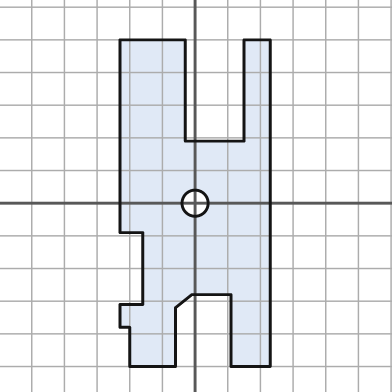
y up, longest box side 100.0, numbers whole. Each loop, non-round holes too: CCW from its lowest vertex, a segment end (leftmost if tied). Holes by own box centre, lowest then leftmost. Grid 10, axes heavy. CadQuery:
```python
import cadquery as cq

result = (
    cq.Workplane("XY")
    .moveTo(-20.0, -50.0)
    .lineTo(-6.0, -50.0)
    .lineTo(-6.0, -32.0)
    .lineTo(-1.0, -28.0)
    .lineTo(11.0, -28.0)
    .lineTo(11.0, -50.0)
    .lineTo(23.0, -50.0)
    .lineTo(23.0, 50.0)
    .lineTo(15.0, 50.0)
    .lineTo(15.0, 19.0)
    .lineTo(-3.0, 19.0)
    .lineTo(-3.0, 50.0)
    .lineTo(-23.0, 50.0)
    .lineTo(-23.0, -9.0)
    .lineTo(-16.0, -9.0)
    .lineTo(-16.0, -31.0)
    .lineTo(-23.0, -31.0)
    .lineTo(-23.0, -38.0)
    .lineTo(-20.0, -38.0)
    .close()
    .moveTo(0.0, 0.0)
    .circle(4.0)
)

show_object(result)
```